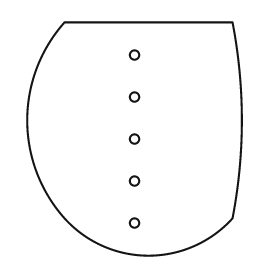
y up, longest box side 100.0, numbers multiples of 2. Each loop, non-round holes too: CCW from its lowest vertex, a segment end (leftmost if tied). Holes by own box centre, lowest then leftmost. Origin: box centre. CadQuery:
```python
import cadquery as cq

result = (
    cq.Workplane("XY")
    .moveTo(-30.0, -34.0)
    .threePointArc((6.0, -50.0), (42.0, -34.0))
    .threePointArc((46.0, 8.0), (42.0, 50.0))
    .lineTo(-30.0, 50.0)
    .threePointArc((-46.0, 8.0), (-30.0, -34.0))
    .close()
    .moveTo(0.0, -36.0)
    .circle(2.0)
    .moveTo(0.0, -18.0)
    .circle(2.0)
    .moveTo(0.0, 0.0)
    .circle(2.0)
    .moveTo(0.0, 18.0)
    .circle(2.0)
    .moveTo(0.0, 36.0)
    .circle(2.0)
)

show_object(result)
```